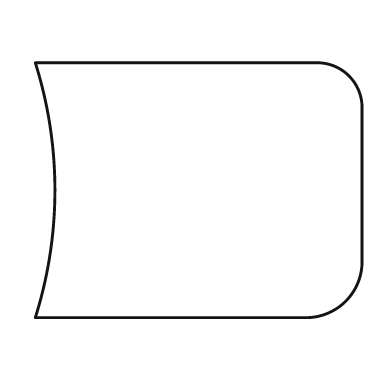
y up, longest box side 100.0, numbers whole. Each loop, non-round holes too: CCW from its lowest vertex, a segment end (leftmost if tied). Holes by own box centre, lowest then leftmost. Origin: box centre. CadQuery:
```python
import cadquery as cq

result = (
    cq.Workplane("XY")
    .moveTo(-50.0, -39.0)
    .lineTo(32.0, -39.0)
    .threePointArc((45.0, -34.0), (50.0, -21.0))
    .lineTo(50.0, 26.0)
    .threePointArc((46.0, 35.0), (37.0, 39.0))
    .lineTo(-50.0, 39.0)
    .threePointArc((-44.0, 0.0), (-50.0, -39.0))
    .close()
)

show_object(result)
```